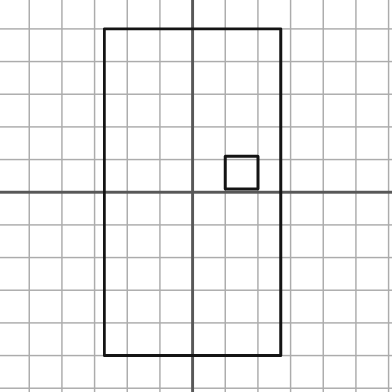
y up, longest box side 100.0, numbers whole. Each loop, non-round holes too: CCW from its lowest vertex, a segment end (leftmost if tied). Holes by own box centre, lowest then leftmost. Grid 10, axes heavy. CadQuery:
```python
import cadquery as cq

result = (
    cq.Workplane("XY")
    .moveTo(-27.0, -50.0)
    .lineTo(27.0, -50.0)
    .lineTo(27.0, 50.0)
    .lineTo(-27.0, 50.0)
    .close()
    .moveTo(10.0, 1.0)
    .lineTo(20.0, 1.0)
    .lineTo(20.0, 11.0)
    .lineTo(10.0, 11.0)
    .close()
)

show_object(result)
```